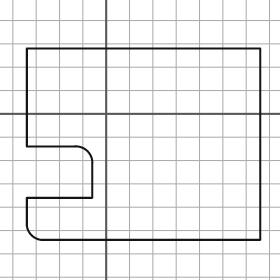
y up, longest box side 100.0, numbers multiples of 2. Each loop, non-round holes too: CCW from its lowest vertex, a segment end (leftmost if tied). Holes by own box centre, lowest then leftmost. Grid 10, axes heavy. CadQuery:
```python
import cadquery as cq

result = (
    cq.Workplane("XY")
    .moveTo(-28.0, -54.0)
    .lineTo(66.0, -54.0)
    .lineTo(66.0, 28.0)
    .lineTo(-34.0, 28.0)
    .lineTo(-34.0, -14.0)
    .lineTo(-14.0, -14.0)
    .threePointArc((-8.0, -16.0), (-6.0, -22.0))
    .lineTo(-6.0, -36.0)
    .lineTo(-34.0, -36.0)
    .lineTo(-34.0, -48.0)
    .threePointArc((-32.0, -52.0), (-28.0, -54.0))
    .close()
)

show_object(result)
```